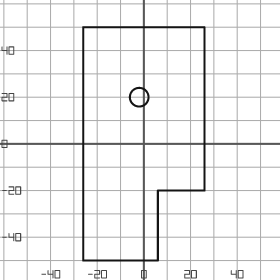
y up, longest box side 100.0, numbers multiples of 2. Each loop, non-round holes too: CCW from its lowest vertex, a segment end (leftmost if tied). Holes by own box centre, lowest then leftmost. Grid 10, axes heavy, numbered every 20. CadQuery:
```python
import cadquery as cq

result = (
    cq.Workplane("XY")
    .moveTo(-26.0, -50.0)
    .lineTo(6.0, -50.0)
    .lineTo(6.0, -20.0)
    .lineTo(26.0, -20.0)
    .lineTo(26.0, 50.0)
    .lineTo(-26.0, 50.0)
    .close()
    .moveTo(-2.0, 20.0)
    .circle(4.0)
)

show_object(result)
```